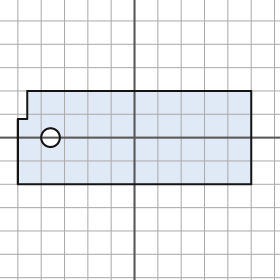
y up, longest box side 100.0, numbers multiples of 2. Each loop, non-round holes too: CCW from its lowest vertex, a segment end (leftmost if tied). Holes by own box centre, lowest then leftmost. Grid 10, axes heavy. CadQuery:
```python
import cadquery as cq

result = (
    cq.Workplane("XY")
    .moveTo(-50.0, -20.0)
    .lineTo(50.0, -20.0)
    .lineTo(50.0, 20.0)
    .lineTo(-46.0, 20.0)
    .lineTo(-46.0, 8.0)
    .lineTo(-50.0, 8.0)
    .close()
    .moveTo(-36.0, 0.0)
    .circle(4.0)
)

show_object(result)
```